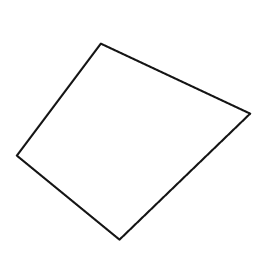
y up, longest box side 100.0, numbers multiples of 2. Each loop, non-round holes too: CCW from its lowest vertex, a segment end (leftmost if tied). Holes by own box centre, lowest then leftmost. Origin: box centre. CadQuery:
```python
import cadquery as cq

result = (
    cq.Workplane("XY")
    .moveTo(-6.0, -42.0)
    .lineTo(50.0, 12.0)
    .lineTo(-14.0, 42.0)
    .lineTo(-50.0, -6.0)
    .close()
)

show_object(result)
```